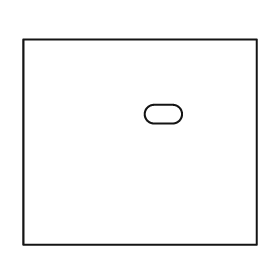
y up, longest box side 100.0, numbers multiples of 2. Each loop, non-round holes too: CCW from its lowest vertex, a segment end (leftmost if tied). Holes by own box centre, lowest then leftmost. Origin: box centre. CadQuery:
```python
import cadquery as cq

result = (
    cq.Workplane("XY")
    .moveTo(-50.0, -44.0)
    .lineTo(50.0, -44.0)
    .lineTo(50.0, 44.0)
    .lineTo(-50.0, 44.0)
    .close()
    .moveTo(6.0, 8.0)
    .lineTo(14.0, 8.0)
    .threePointArc((18.0, 12.0), (14.0, 16.0))
    .lineTo(6.0, 16.0)
    .threePointArc((2.0, 12.0), (6.0, 8.0))
    .close()
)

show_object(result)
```